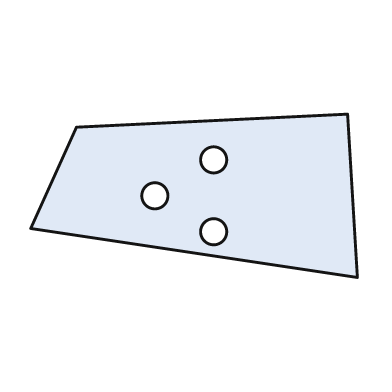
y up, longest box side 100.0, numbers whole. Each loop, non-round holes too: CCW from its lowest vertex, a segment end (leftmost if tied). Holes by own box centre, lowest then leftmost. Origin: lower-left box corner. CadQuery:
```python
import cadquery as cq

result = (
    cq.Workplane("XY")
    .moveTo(100.0, 0.0)
    .lineTo(97.0, 50.0)
    .lineTo(14.0, 46.0)
    .lineTo(0.0, 15.0)
    .close()
    .moveTo(56.0, 14.0)
    .circle(4.0)
    .moveTo(38.0, 25.0)
    .circle(4.0)
    .moveTo(56.0, 36.0)
    .circle(4.0)
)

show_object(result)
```